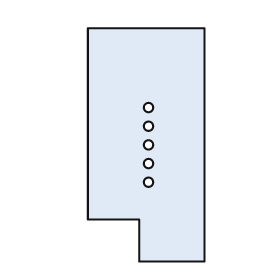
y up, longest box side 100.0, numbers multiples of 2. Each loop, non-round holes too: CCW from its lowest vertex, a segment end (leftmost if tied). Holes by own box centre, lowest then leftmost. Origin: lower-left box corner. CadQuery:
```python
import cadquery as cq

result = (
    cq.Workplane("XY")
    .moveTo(22.0, 0.0)
    .lineTo(50.0, 0.0)
    .lineTo(50.0, 100.0)
    .lineTo(0.0, 100.0)
    .lineTo(0.0, 18.0)
    .lineTo(22.0, 18.0)
    .close()
    .moveTo(26.0, 34.0)
    .circle(2.0)
    .moveTo(26.0, 42.0)
    .circle(2.0)
    .moveTo(26.0, 50.0)
    .circle(2.0)
    .moveTo(26.0, 58.0)
    .circle(2.0)
    .moveTo(26.0, 66.0)
    .circle(2.0)
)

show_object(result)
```